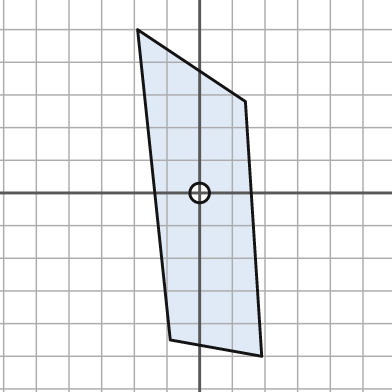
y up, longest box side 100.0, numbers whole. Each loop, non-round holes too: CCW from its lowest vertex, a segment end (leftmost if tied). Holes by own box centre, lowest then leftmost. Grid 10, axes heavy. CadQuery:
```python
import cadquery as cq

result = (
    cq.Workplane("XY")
    .moveTo(19.0, -50.0)
    .lineTo(14.0, 28.0)
    .lineTo(-19.0, 50.0)
    .lineTo(-9.0, -45.0)
    .close()
    .moveTo(0.0, 0.0)
    .circle(3.0)
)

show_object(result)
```